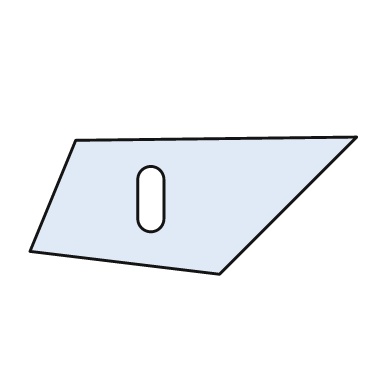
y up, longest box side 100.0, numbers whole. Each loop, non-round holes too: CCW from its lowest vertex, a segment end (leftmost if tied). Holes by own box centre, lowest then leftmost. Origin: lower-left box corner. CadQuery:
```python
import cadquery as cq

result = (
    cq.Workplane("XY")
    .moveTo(58.0, 0.0)
    .lineTo(100.0, 42.0)
    .lineTo(14.0, 41.0)
    .lineTo(0.0, 7.0)
    .close()
    .moveTo(33.0, 17.0)
    .threePointArc((37.0, 13.0), (41.0, 17.0))
    .lineTo(41.0, 29.0)
    .threePointArc((37.0, 33.0), (33.0, 29.0))
    .close()
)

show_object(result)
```